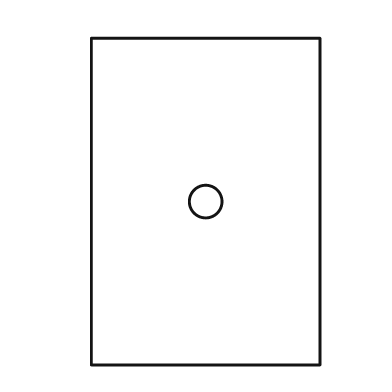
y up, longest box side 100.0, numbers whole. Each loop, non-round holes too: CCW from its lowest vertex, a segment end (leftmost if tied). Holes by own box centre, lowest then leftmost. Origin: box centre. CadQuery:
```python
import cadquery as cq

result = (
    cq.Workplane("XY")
    .moveTo(-35.0, -50.0)
    .lineTo(35.0, -50.0)
    .lineTo(35.0, 50.0)
    .lineTo(-35.0, 50.0)
    .close()
    .moveTo(0.0, 0.0)
    .circle(5.0)
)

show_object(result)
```